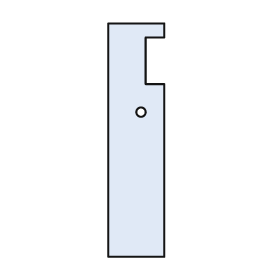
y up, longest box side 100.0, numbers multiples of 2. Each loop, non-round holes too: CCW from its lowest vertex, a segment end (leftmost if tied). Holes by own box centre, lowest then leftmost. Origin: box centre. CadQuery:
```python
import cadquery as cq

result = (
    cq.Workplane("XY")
    .moveTo(-12.0, -50.0)
    .lineTo(12.0, -50.0)
    .lineTo(12.0, 24.0)
    .lineTo(4.0, 24.0)
    .lineTo(4.0, 44.0)
    .lineTo(12.0, 44.0)
    .lineTo(12.0, 50.0)
    .lineTo(-12.0, 50.0)
    .close()
    .moveTo(2.0, 12.0)
    .circle(2.0)
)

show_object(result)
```